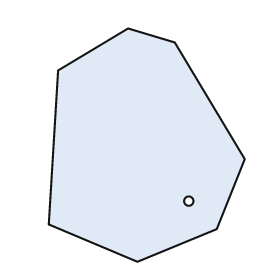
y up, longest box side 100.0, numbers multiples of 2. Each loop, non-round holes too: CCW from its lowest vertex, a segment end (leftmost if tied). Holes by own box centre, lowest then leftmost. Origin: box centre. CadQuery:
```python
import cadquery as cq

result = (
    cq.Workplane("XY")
    .moveTo(-4.0, -50.0)
    .lineTo(30.0, -36.0)
    .lineTo(42.0, -6.0)
    .lineTo(12.0, 44.0)
    .lineTo(-8.0, 50.0)
    .lineTo(-38.0, 32.0)
    .lineTo(-42.0, -34.0)
    .close()
    .moveTo(18.0, -24.0)
    .circle(2.0)
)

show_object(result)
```